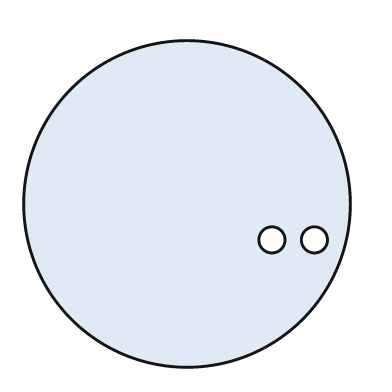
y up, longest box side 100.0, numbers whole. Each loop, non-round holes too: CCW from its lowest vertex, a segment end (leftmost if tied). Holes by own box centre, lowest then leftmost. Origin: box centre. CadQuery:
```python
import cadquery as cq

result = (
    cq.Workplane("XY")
    .moveTo(0.0, 0.0)
    .circle(50.0)
    .moveTo(26.0, -11.0)
    .circle(4.0)
    .moveTo(39.0, -11.0)
    .circle(4.0)
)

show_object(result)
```